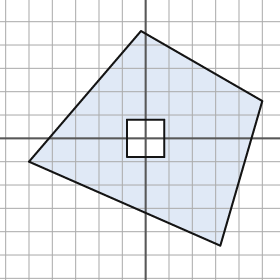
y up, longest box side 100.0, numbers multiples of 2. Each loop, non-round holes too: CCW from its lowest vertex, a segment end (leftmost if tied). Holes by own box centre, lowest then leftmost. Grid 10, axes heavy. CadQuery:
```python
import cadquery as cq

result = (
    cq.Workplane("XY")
    .moveTo(32.0, -46.0)
    .lineTo(50.0, 16.0)
    .lineTo(-2.0, 46.0)
    .lineTo(-50.0, -10.0)
    .close()
    .moveTo(-8.0, -8.0)
    .lineTo(8.0, -8.0)
    .lineTo(8.0, 8.0)
    .lineTo(-8.0, 8.0)
    .close()
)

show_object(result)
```